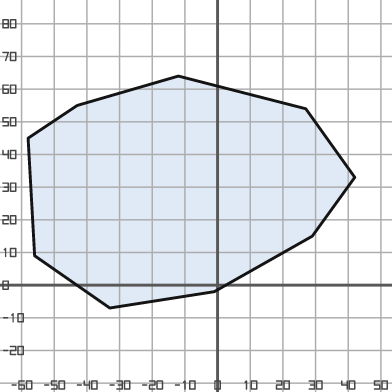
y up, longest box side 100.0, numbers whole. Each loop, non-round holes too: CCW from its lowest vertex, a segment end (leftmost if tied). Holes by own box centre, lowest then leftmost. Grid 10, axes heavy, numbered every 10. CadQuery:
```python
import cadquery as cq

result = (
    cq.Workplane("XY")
    .moveTo(-33.0, -7.0)
    .lineTo(-1.0, -2.0)
    .lineTo(29.0, 15.0)
    .lineTo(42.0, 33.0)
    .lineTo(27.0, 54.0)
    .lineTo(-12.0, 64.0)
    .lineTo(-43.0, 55.0)
    .lineTo(-58.0, 45.0)
    .lineTo(-56.0, 9.0)
    .close()
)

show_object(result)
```